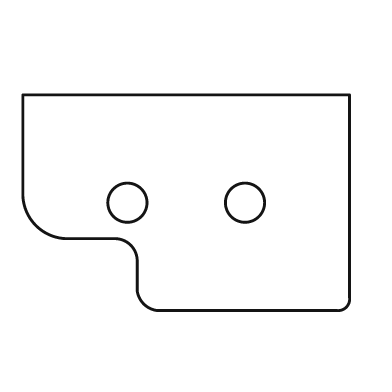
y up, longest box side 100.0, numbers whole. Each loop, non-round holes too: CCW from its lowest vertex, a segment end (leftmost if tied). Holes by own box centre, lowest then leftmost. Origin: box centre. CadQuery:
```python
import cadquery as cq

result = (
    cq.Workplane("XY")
    .moveTo(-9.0, -33.0)
    .lineTo(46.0, -33.0)
    .threePointArc((49.0, -32.0), (50.0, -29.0))
    .lineTo(50.0, 33.0)
    .lineTo(-50.0, 33.0)
    .lineTo(-50.0, 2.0)
    .threePointArc((-46.0, -7.0), (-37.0, -11.0))
    .lineTo(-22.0, -11.0)
    .threePointArc((-17.0, -13.0), (-15.0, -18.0))
    .lineTo(-15.0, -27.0)
    .threePointArc((-13.0, -31.0), (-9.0, -33.0))
    .close()
    .moveTo(-18.0, 0.0)
    .circle(6.0)
    .moveTo(18.0, 0.0)
    .circle(6.0)
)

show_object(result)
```